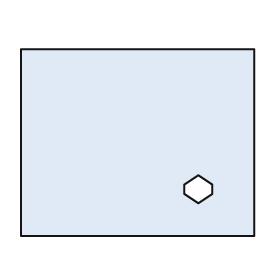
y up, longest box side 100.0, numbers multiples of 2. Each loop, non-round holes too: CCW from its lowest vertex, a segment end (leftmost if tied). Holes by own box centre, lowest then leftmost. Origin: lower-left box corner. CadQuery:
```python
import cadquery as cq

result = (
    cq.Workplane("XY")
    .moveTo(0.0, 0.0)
    .lineTo(100.0, 0.0)
    .lineTo(100.0, 80.0)
    .lineTo(0.0, 80.0)
    .close()
    .moveTo(76.0, 14.0)
    .lineTo(82.0, 18.0)
    .lineTo(82.0, 22.0)
    .lineTo(76.0, 26.0)
    .lineTo(70.0, 22.0)
    .lineTo(70.0, 18.0)
    .close()
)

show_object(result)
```